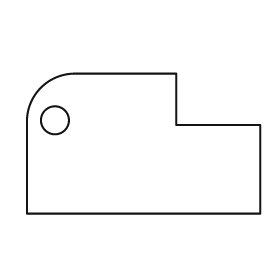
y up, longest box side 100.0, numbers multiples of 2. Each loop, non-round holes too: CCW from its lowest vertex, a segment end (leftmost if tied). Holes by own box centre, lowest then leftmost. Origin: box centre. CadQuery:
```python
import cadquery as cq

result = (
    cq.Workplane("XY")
    .moveTo(-50.0, -30.0)
    .lineTo(50.0, -30.0)
    .lineTo(50.0, 8.0)
    .lineTo(14.0, 8.0)
    .lineTo(14.0, 30.0)
    .lineTo(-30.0, 30.0)
    .threePointArc((-44.0, 24.0), (-50.0, 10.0))
    .close()
    .moveTo(-38.0, 10.0)
    .circle(6.0)
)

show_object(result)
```